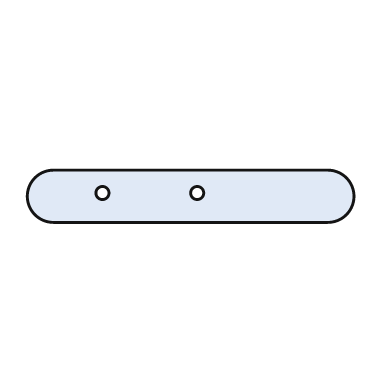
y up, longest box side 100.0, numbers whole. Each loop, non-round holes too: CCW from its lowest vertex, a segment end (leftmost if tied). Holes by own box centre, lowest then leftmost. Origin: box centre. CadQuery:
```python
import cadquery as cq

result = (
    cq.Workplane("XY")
    .moveTo(-42.0, -8.0)
    .lineTo(42.0, -8.0)
    .threePointArc((50.0, 0.0), (42.0, 8.0))
    .lineTo(-42.0, 8.0)
    .threePointArc((-50.0, 0.0), (-42.0, -8.0))
    .close()
    .moveTo(-27.0, 1.0)
    .circle(2.0)
    .moveTo(2.0, 1.0)
    .circle(2.0)
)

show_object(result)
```